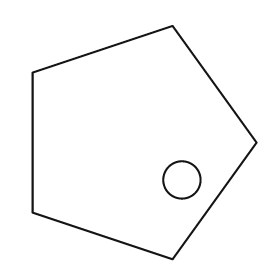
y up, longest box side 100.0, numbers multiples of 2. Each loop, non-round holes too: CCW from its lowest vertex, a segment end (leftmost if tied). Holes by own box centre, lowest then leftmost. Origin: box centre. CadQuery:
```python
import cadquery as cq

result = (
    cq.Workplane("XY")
    .moveTo(12.0, -50.0)
    .lineTo(48.0, 0.0)
    .lineTo(12.0, 50.0)
    .lineTo(-48.0, 30.0)
    .lineTo(-48.0, -30.0)
    .close()
    .moveTo(16.0, -16.0)
    .circle(8.0)
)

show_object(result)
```